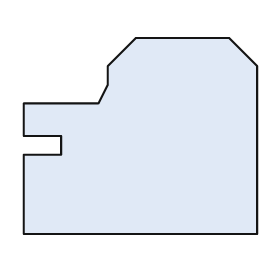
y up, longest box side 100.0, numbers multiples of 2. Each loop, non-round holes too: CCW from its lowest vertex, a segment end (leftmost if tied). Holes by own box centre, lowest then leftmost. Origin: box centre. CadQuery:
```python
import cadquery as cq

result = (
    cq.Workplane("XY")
    .moveTo(-50.0, -42.0)
    .lineTo(50.0, -42.0)
    .lineTo(50.0, 30.0)
    .lineTo(38.0, 42.0)
    .lineTo(-2.0, 42.0)
    .lineTo(-14.0, 30.0)
    .lineTo(-14.0, 22.0)
    .lineTo(-18.0, 14.0)
    .lineTo(-50.0, 14.0)
    .lineTo(-50.0, 0.0)
    .lineTo(-34.0, 0.0)
    .lineTo(-34.0, -8.0)
    .lineTo(-50.0, -8.0)
    .close()
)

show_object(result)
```